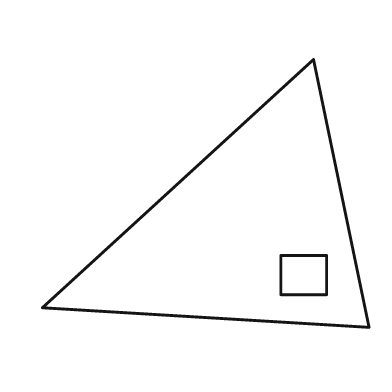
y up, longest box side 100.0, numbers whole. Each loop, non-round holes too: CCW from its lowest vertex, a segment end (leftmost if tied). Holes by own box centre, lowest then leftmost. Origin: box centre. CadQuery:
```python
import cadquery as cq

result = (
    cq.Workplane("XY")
    .moveTo(50.0, -41.0)
    .lineTo(33.0, 41.0)
    .lineTo(-50.0, -35.0)
    .close()
    .moveTo(23.0, -31.0)
    .lineTo(37.0, -31.0)
    .lineTo(37.0, -19.0)
    .lineTo(23.0, -19.0)
    .close()
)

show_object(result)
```